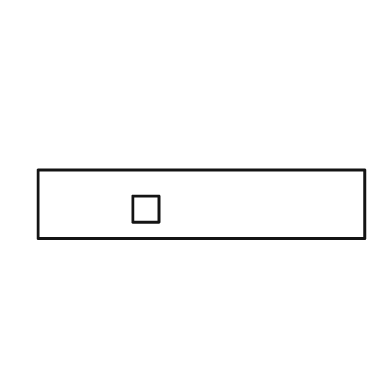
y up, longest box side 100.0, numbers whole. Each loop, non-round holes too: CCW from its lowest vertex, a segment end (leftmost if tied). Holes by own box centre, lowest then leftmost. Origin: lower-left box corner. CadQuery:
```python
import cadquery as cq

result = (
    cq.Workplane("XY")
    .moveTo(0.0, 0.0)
    .lineTo(100.0, 0.0)
    .lineTo(100.0, 21.0)
    .lineTo(0.0, 21.0)
    .close()
    .moveTo(29.0, 5.0)
    .lineTo(37.0, 5.0)
    .lineTo(37.0, 13.0)
    .lineTo(29.0, 13.0)
    .close()
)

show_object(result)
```